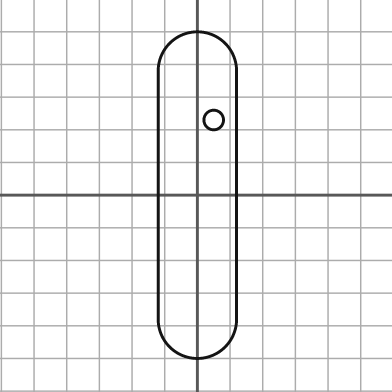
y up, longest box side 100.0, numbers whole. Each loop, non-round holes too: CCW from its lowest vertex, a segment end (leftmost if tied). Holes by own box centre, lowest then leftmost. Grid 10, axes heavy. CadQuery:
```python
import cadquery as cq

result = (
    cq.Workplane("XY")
    .moveTo(-12.0, -38.0)
    .threePointArc((0.0, -50.0), (12.0, -38.0))
    .lineTo(12.0, 38.0)
    .threePointArc((0.0, 50.0), (-12.0, 38.0))
    .close()
    .moveTo(5.0, 23.0)
    .circle(3.0)
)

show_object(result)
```